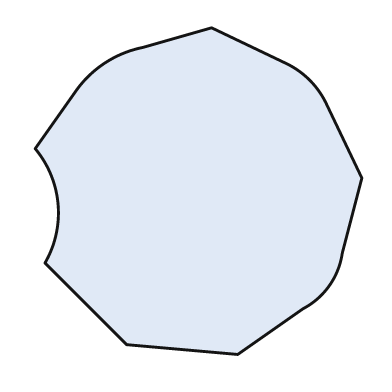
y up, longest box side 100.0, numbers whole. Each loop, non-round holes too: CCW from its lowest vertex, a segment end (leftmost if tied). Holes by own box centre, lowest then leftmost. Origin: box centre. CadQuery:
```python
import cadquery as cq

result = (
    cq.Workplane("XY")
    .moveTo(12.0, -50.0)
    .lineTo(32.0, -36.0)
    .threePointArc((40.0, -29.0), (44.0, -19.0))
    .lineTo(50.0, 4.0)
    .lineTo(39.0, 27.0)
    .threePointArc((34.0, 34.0), (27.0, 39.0))
    .lineTo(4.0, 50.0)
    .lineTo(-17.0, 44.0)
    .threePointArc((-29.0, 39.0), (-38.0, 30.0))
    .lineTo(-50.0, 13.0)
    .threePointArc((-43.0, -4.0), (-47.0, -22.0))
    .lineTo(-22.0, -47.0)
    .close()
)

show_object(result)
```